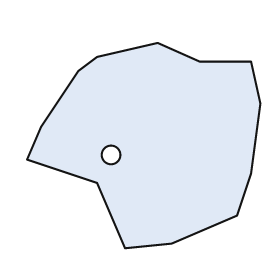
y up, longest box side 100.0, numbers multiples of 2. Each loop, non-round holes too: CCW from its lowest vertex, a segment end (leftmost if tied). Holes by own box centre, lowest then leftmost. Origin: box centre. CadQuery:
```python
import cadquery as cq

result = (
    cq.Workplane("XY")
    .moveTo(-8.0, -44.0)
    .lineTo(12.0, -42.0)
    .lineTo(40.0, -30.0)
    .lineTo(46.0, -12.0)
    .lineTo(50.0, 18.0)
    .lineTo(46.0, 36.0)
    .lineTo(24.0, 36.0)
    .lineTo(6.0, 44.0)
    .lineTo(-20.0, 38.0)
    .lineTo(-28.0, 32.0)
    .lineTo(-44.0, 8.0)
    .lineTo(-50.0, -6.0)
    .lineTo(-20.0, -16.0)
    .close()
    .moveTo(-14.0, -4.0)
    .circle(4.0)
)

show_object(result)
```